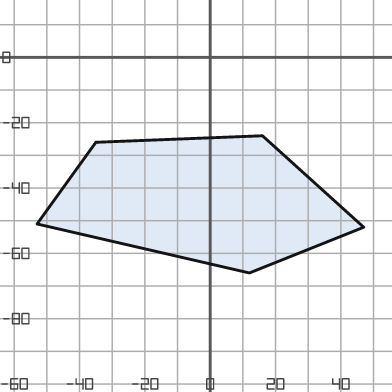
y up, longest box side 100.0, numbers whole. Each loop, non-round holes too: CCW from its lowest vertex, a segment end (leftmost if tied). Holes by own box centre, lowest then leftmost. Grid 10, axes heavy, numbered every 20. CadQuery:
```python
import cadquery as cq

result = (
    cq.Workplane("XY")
    .moveTo(12.0, -66.0)
    .lineTo(47.0, -52.0)
    .lineTo(16.0, -24.0)
    .lineTo(-35.0, -26.0)
    .lineTo(-53.0, -51.0)
    .close()
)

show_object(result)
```